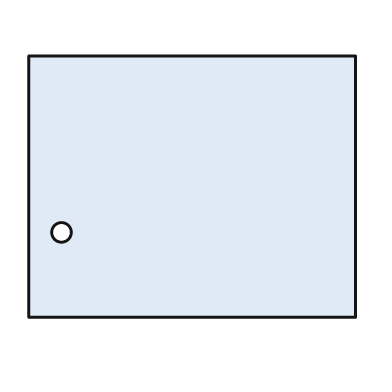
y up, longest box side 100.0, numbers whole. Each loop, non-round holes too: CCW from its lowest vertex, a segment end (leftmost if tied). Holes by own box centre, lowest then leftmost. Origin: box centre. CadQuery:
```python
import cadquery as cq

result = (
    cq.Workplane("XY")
    .moveTo(-50.0, -40.0)
    .lineTo(50.0, -40.0)
    .lineTo(50.0, 40.0)
    .lineTo(-50.0, 40.0)
    .close()
    .moveTo(-40.0, -14.0)
    .circle(3.0)
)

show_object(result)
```